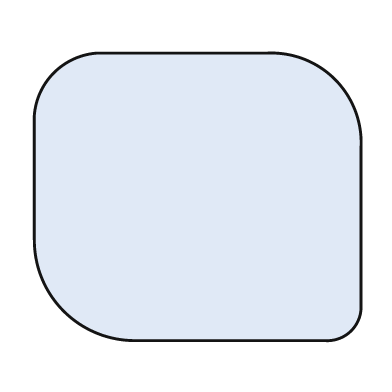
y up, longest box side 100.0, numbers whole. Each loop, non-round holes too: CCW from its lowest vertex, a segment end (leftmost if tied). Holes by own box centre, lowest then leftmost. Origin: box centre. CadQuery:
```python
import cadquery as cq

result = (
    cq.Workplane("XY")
    .moveTo(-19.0, -44.0)
    .lineTo(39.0, -44.0)
    .threePointArc((47.0, -41.0), (50.0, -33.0))
    .lineTo(50.0, 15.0)
    .threePointArc((42.0, 36.0), (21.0, 44.0))
    .lineTo(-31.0, 44.0)
    .threePointArc((-44.0, 38.0), (-50.0, 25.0))
    .lineTo(-50.0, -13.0)
    .threePointArc((-41.0, -35.0), (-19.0, -44.0))
    .close()
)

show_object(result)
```